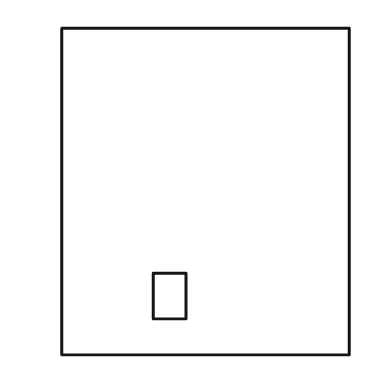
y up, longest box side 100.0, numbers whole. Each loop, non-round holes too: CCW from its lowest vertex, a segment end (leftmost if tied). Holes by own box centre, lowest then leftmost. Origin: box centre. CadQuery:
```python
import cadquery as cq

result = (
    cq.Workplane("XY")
    .moveTo(-44.0, -50.0)
    .lineTo(44.0, -50.0)
    .lineTo(44.0, 50.0)
    .lineTo(-44.0, 50.0)
    .close()
    .moveTo(-16.0, -39.0)
    .lineTo(-6.0, -39.0)
    .lineTo(-6.0, -25.0)
    .lineTo(-16.0, -25.0)
    .close()
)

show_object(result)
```